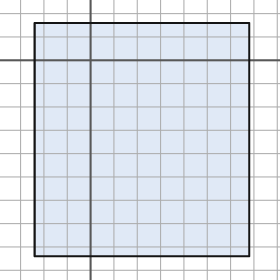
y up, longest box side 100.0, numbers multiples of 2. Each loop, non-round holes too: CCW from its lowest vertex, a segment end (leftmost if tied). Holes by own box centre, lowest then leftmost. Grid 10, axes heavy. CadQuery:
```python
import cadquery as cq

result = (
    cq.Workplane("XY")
    .moveTo(-24.0, -84.0)
    .lineTo(68.0, -84.0)
    .lineTo(68.0, 16.0)
    .lineTo(-24.0, 16.0)
    .close()
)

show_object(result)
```